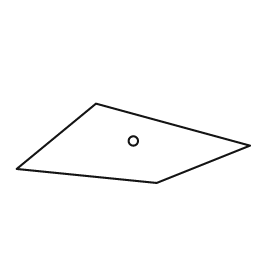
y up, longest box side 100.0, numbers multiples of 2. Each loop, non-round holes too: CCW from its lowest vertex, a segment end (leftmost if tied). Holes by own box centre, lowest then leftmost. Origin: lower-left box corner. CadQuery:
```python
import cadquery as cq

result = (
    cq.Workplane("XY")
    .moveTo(60.0, 0.0)
    .lineTo(100.0, 16.0)
    .lineTo(34.0, 34.0)
    .lineTo(0.0, 6.0)
    .close()
    .moveTo(50.0, 18.0)
    .circle(2.0)
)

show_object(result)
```